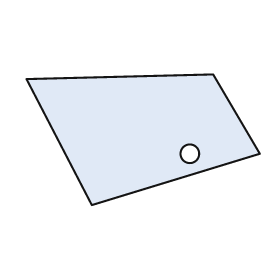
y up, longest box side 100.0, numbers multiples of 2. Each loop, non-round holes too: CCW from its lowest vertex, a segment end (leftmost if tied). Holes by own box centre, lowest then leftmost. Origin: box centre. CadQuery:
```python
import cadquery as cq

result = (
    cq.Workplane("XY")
    .moveTo(-22.0, -28.0)
    .lineTo(50.0, -6.0)
    .lineTo(30.0, 28.0)
    .lineTo(-50.0, 26.0)
    .close()
    .moveTo(20.0, -6.0)
    .circle(4.0)
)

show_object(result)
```